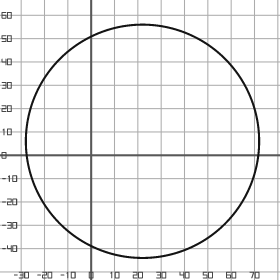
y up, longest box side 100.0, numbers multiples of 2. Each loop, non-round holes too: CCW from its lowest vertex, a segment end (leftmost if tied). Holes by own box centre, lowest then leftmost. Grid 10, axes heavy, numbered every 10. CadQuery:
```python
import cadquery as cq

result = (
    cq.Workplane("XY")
    .moveTo(22.0, 6.0)
    .circle(50.0)
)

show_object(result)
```